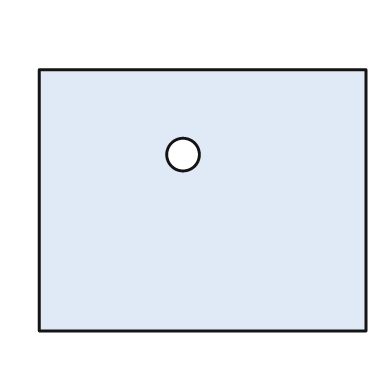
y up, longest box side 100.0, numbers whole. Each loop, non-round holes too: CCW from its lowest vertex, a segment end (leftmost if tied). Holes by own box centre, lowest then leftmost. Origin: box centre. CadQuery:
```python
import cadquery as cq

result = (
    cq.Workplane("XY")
    .moveTo(-50.0, -40.0)
    .lineTo(50.0, -40.0)
    .lineTo(50.0, 40.0)
    .lineTo(-50.0, 40.0)
    .close()
    .moveTo(-6.0, 14.0)
    .circle(5.0)
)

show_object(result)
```